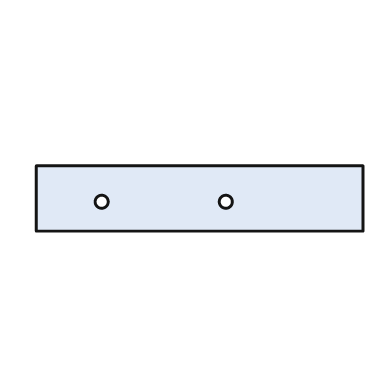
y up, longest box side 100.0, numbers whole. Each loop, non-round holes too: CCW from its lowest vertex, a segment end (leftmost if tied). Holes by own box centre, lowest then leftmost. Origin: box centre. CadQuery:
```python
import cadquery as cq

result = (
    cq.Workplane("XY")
    .moveTo(-50.0, -10.0)
    .lineTo(50.0, -10.0)
    .lineTo(50.0, 10.0)
    .lineTo(-50.0, 10.0)
    .close()
    .moveTo(-30.0, -1.0)
    .circle(2.0)
    .moveTo(8.0, -1.0)
    .circle(2.0)
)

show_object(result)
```